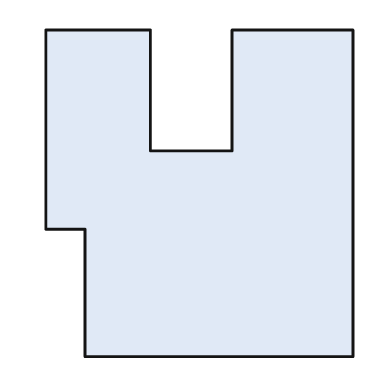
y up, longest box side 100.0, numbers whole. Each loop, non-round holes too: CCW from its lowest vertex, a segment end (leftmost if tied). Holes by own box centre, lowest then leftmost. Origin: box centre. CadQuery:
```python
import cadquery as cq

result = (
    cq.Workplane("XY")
    .moveTo(-35.0, -50.0)
    .lineTo(47.0, -50.0)
    .lineTo(47.0, 50.0)
    .lineTo(10.0, 50.0)
    .lineTo(10.0, 13.0)
    .lineTo(-15.0, 13.0)
    .lineTo(-15.0, 50.0)
    .lineTo(-47.0, 50.0)
    .lineTo(-47.0, -11.0)
    .lineTo(-35.0, -11.0)
    .close()
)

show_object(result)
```